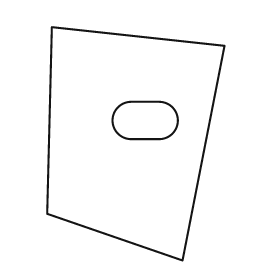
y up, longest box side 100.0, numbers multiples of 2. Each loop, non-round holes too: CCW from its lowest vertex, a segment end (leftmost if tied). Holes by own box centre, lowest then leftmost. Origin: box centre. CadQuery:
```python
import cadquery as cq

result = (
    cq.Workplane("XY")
    .moveTo(20.0, -50.0)
    .lineTo(38.0, 42.0)
    .lineTo(-36.0, 50.0)
    .lineTo(-38.0, -30.0)
    .close()
    .moveTo(-2.0, 2.0)
    .lineTo(10.0, 2.0)
    .threePointArc((18.0, 10.0), (10.0, 18.0))
    .lineTo(-2.0, 18.0)
    .threePointArc((-10.0, 10.0), (-2.0, 2.0))
    .close()
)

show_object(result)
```